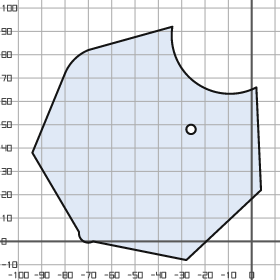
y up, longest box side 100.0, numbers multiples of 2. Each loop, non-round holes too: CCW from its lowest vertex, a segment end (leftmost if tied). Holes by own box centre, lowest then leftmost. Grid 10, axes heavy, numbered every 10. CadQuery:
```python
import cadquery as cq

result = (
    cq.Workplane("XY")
    .moveTo(-28.0, -8.0)
    .lineTo(4.0, 22.0)
    .lineTo(2.0, 66.0)
    .threePointArc((-24.0, 68.0), (-34.0, 92.0))
    .lineTo(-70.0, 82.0)
    .threePointArc((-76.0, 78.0), (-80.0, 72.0))
    .lineTo(-94.0, 38.0)
    .lineTo(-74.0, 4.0)
    .threePointArc((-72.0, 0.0), (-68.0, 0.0))
    .close()
    .moveTo(-26.0, 48.0)
    .circle(2.0)
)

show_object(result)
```